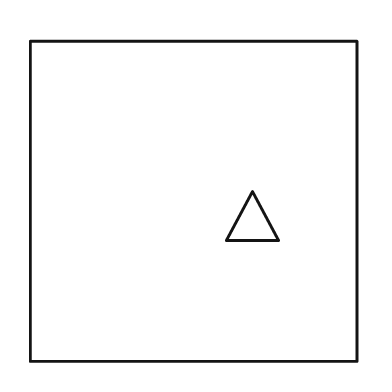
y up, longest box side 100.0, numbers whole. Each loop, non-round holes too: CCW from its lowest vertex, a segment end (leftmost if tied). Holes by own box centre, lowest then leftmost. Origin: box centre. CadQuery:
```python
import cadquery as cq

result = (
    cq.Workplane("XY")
    .moveTo(-50.0, -49.0)
    .lineTo(50.0, -49.0)
    .lineTo(50.0, 49.0)
    .lineTo(-50.0, 49.0)
    .close()
    .moveTo(10.0, -12.0)
    .lineTo(26.0, -12.0)
    .lineTo(18.0, 3.0)
    .close()
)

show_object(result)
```